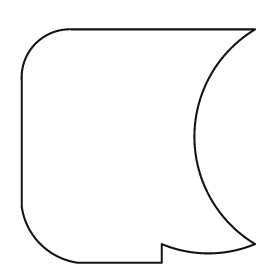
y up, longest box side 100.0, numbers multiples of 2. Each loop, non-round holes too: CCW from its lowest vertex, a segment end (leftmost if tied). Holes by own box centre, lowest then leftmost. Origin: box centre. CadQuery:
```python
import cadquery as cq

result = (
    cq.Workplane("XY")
    .moveTo(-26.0, -50.0)
    .lineTo(10.0, -50.0)
    .lineTo(10.0, -42.0)
    .threePointArc((30.0, -46.0), (50.0, -42.0))
    .threePointArc((24.0, 4.0), (50.0, 50.0))
    .lineTo(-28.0, 50.0)
    .threePointArc((-44.0, 44.0), (-50.0, 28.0))
    .lineTo(-50.0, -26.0)
    .threePointArc((-42.0, -42.0), (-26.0, -50.0))
    .close()
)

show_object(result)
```